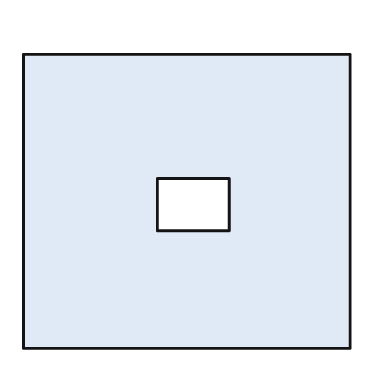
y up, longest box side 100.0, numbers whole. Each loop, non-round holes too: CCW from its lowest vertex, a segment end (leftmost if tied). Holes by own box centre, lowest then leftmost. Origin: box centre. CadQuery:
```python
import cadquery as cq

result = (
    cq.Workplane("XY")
    .moveTo(-50.0, -45.0)
    .lineTo(50.0, -45.0)
    .lineTo(50.0, 45.0)
    .lineTo(-50.0, 45.0)
    .close()
    .moveTo(-9.0, -9.0)
    .lineTo(13.0, -9.0)
    .lineTo(13.0, 7.0)
    .lineTo(-9.0, 7.0)
    .close()
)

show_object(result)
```